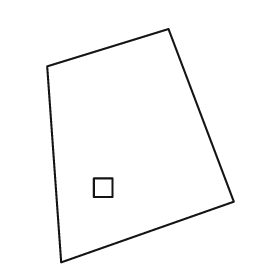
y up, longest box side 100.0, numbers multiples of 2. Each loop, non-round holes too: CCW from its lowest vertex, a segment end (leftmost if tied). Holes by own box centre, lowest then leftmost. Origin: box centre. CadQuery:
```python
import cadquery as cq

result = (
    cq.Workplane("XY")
    .moveTo(-34.0, -50.0)
    .lineTo(40.0, -24.0)
    .lineTo(12.0, 50.0)
    .lineTo(-40.0, 34.0)
    .close()
    .moveTo(-20.0, -22.0)
    .lineTo(-12.0, -22.0)
    .lineTo(-12.0, -14.0)
    .lineTo(-20.0, -14.0)
    .close()
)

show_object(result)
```